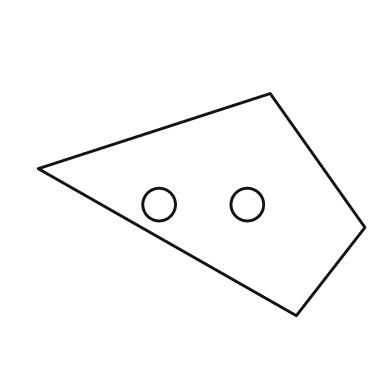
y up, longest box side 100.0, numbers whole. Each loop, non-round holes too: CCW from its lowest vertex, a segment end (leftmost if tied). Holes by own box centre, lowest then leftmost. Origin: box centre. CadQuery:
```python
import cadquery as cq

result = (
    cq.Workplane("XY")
    .moveTo(29.0, -34.0)
    .lineTo(50.0, -7.0)
    .lineTo(21.0, 34.0)
    .lineTo(-50.0, 11.0)
    .close()
    .moveTo(-13.0, 0.0)
    .circle(5.0)
    .moveTo(14.0, 0.0)
    .circle(5.0)
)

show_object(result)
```